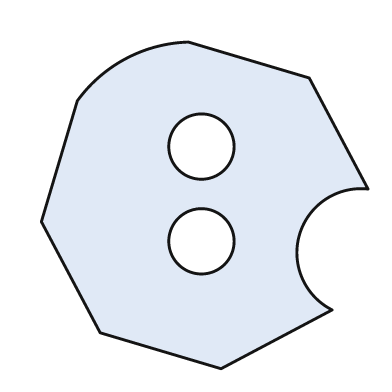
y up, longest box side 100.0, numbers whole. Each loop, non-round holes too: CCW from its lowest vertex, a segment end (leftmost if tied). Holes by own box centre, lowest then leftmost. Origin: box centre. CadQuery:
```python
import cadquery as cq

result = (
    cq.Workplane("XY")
    .moveTo(5.0, -50.0)
    .lineTo(39.0, -32.0)
    .threePointArc((29.0, -9.0), (50.0, 5.0))
    .lineTo(32.0, 39.0)
    .lineTo(-5.0, 50.0)
    .threePointArc((-24.0, 45.0), (-39.0, 32.0))
    .lineTo(-50.0, -5.0)
    .lineTo(-32.0, -39.0)
    .close()
    .moveTo(-1.0, -11.0)
    .circle(10.0)
    .moveTo(-1.0, 18.0)
    .circle(10.0)
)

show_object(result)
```